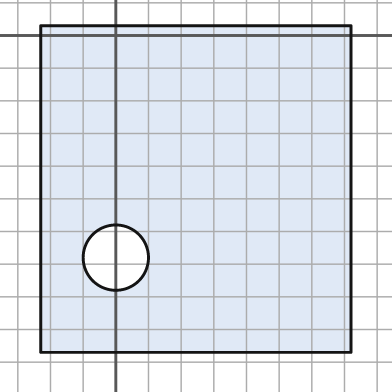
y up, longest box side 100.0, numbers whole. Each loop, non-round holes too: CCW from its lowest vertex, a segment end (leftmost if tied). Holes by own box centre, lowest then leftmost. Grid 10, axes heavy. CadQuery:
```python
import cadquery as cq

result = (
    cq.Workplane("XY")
    .moveTo(-23.0, -97.0)
    .lineTo(72.0, -97.0)
    .lineTo(72.0, 3.0)
    .lineTo(-23.0, 3.0)
    .close()
    .moveTo(0.0, -68.0)
    .circle(10.0)
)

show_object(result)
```